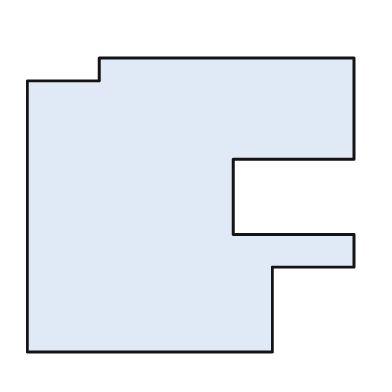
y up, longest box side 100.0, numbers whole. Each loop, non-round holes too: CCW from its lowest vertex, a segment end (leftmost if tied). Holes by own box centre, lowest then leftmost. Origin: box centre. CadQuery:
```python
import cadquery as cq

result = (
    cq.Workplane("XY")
    .moveTo(-50.0, -45.0)
    .lineTo(25.0, -45.0)
    .lineTo(25.0, -19.0)
    .lineTo(50.0, -19.0)
    .lineTo(50.0, -9.0)
    .lineTo(13.0, -9.0)
    .lineTo(13.0, 14.0)
    .lineTo(50.0, 14.0)
    .lineTo(50.0, 45.0)
    .lineTo(-28.0, 45.0)
    .lineTo(-28.0, 38.0)
    .lineTo(-50.0, 38.0)
    .close()
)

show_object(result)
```